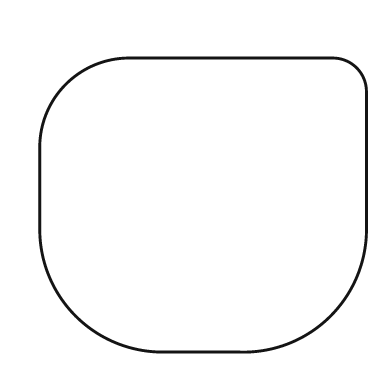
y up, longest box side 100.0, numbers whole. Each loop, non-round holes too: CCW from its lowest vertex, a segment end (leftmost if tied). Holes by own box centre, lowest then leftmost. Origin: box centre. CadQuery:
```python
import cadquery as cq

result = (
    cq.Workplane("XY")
    .moveTo(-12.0, -45.0)
    .lineTo(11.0, -45.0)
    .threePointArc((39.0, -34.0), (50.0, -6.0))
    .lineTo(50.0, 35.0)
    .threePointArc((47.0, 42.0), (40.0, 45.0))
    .lineTo(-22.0, 45.0)
    .threePointArc((-42.0, 37.0), (-50.0, 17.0))
    .lineTo(-50.0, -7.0)
    .threePointArc((-39.0, -34.0), (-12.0, -45.0))
    .close()
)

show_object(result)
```